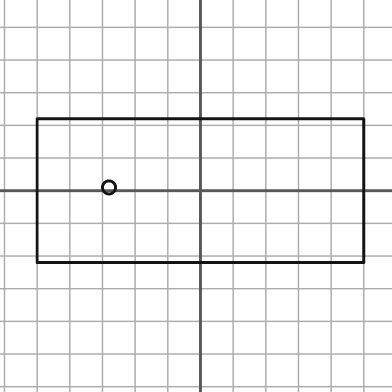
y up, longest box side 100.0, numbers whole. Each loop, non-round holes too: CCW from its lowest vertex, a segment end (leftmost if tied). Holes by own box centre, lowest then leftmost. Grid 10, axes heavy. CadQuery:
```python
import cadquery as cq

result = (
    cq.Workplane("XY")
    .moveTo(-50.0, -22.0)
    .lineTo(50.0, -22.0)
    .lineTo(50.0, 22.0)
    .lineTo(-50.0, 22.0)
    .close()
    .moveTo(-28.0, 1.0)
    .circle(2.0)
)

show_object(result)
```